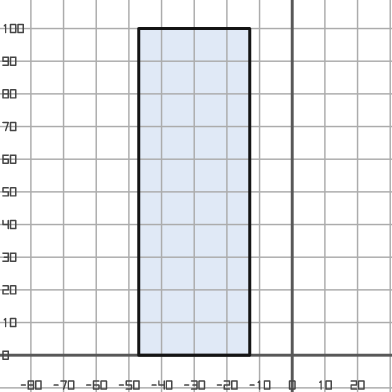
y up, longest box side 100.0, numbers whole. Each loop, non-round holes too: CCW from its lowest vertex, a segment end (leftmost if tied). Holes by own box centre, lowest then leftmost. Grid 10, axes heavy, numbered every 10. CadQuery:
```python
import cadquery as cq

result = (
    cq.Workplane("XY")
    .moveTo(-47.0, 0.0)
    .lineTo(-13.0, 0.0)
    .lineTo(-13.0, 100.0)
    .lineTo(-47.0, 100.0)
    .close()
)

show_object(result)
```